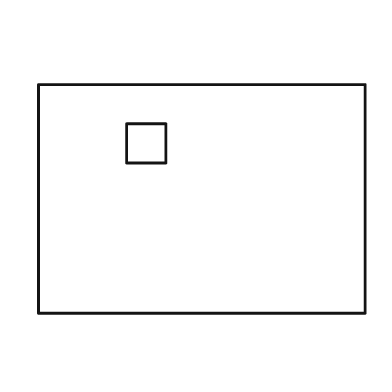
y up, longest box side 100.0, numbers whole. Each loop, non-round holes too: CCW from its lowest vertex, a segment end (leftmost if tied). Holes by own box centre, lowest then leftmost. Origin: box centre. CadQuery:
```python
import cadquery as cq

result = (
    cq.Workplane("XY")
    .moveTo(-50.0, -35.0)
    .lineTo(50.0, -35.0)
    .lineTo(50.0, 35.0)
    .lineTo(-50.0, 35.0)
    .close()
    .moveTo(-23.0, 11.0)
    .lineTo(-11.0, 11.0)
    .lineTo(-11.0, 23.0)
    .lineTo(-23.0, 23.0)
    .close()
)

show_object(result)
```